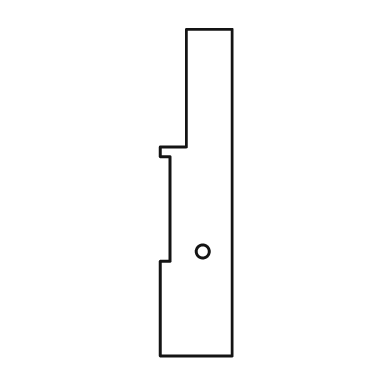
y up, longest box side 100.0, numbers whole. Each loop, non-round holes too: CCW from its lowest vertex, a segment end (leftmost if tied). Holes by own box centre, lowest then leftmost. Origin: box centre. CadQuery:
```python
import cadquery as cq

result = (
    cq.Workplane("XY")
    .moveTo(-11.0, -50.0)
    .lineTo(11.0, -50.0)
    .lineTo(11.0, 50.0)
    .lineTo(-3.0, 50.0)
    .lineTo(-3.0, 14.0)
    .lineTo(-11.0, 14.0)
    .lineTo(-11.0, 11.0)
    .lineTo(-8.0, 11.0)
    .lineTo(-8.0, -21.0)
    .lineTo(-11.0, -21.0)
    .close()
    .moveTo(2.0, -18.0)
    .circle(2.0)
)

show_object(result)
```